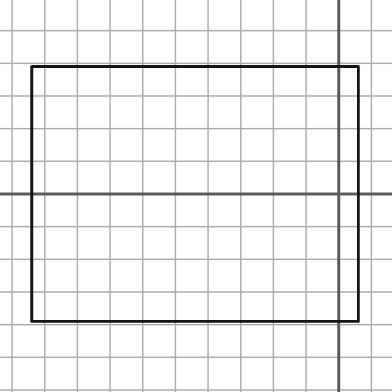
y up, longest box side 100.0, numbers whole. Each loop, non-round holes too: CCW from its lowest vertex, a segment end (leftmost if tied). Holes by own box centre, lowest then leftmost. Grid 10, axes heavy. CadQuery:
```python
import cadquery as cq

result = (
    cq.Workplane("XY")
    .moveTo(-94.0, -39.0)
    .lineTo(6.0, -39.0)
    .lineTo(6.0, 39.0)
    .lineTo(-94.0, 39.0)
    .close()
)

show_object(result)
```